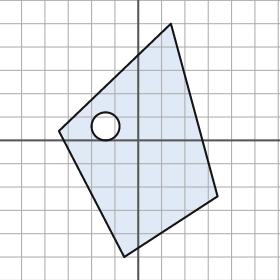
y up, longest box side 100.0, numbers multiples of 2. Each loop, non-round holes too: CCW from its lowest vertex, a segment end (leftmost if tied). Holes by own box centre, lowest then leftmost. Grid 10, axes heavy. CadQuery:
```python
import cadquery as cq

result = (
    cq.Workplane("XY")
    .moveTo(-6.0, -50.0)
    .lineTo(34.0, -24.0)
    .lineTo(14.0, 50.0)
    .lineTo(-34.0, 4.0)
    .close()
    .moveTo(-14.0, 6.0)
    .circle(6.0)
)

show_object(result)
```